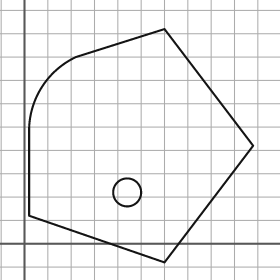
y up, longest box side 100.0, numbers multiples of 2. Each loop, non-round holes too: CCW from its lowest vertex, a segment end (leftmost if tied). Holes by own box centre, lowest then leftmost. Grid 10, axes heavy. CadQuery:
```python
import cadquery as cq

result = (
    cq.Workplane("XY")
    .moveTo(60.0, -8.0)
    .lineTo(98.0, 42.0)
    .lineTo(60.0, 92.0)
    .lineTo(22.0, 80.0)
    .threePointArc((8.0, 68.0), (2.0, 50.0))
    .lineTo(2.0, 12.0)
    .close()
    .moveTo(44.0, 22.0)
    .circle(6.0)
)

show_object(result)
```